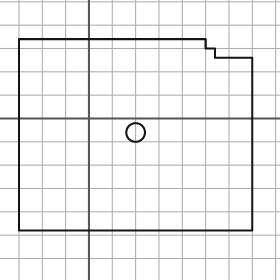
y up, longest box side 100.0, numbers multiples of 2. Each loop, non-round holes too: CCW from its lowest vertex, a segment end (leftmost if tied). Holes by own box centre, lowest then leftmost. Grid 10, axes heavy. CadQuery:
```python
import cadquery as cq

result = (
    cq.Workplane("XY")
    .moveTo(-30.0, -48.0)
    .lineTo(70.0, -48.0)
    .lineTo(70.0, 26.0)
    .lineTo(54.0, 26.0)
    .lineTo(54.0, 30.0)
    .lineTo(50.0, 30.0)
    .lineTo(50.0, 34.0)
    .lineTo(-30.0, 34.0)
    .close()
    .moveTo(20.0, -6.0)
    .circle(4.0)
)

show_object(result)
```